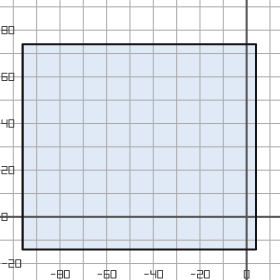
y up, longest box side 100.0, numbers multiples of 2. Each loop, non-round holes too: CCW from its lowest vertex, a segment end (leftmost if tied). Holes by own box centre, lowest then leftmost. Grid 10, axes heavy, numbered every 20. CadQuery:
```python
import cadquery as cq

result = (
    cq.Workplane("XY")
    .moveTo(-96.0, -14.0)
    .lineTo(4.0, -14.0)
    .lineTo(4.0, 74.0)
    .lineTo(-96.0, 74.0)
    .close()
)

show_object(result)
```